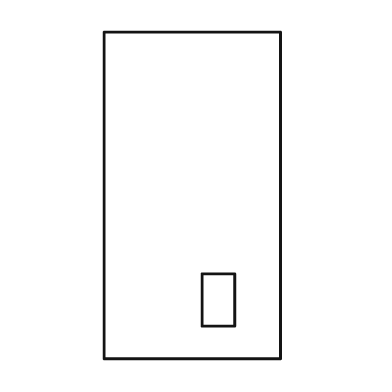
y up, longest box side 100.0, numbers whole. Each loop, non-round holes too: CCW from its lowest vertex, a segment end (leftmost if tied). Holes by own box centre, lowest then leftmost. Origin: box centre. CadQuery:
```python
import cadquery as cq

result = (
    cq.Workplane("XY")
    .moveTo(-27.0, -50.0)
    .lineTo(27.0, -50.0)
    .lineTo(27.0, 50.0)
    .lineTo(-27.0, 50.0)
    .close()
    .moveTo(3.0, -40.0)
    .lineTo(13.0, -40.0)
    .lineTo(13.0, -24.0)
    .lineTo(3.0, -24.0)
    .close()
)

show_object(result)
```